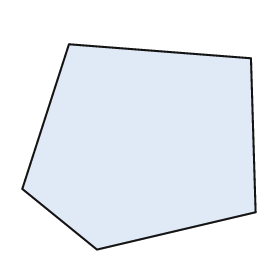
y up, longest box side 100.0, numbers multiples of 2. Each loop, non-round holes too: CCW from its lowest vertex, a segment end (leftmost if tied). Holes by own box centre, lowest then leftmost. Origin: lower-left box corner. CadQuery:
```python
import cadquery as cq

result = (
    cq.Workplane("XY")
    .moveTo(32.0, 0.0)
    .lineTo(100.0, 16.0)
    .lineTo(98.0, 82.0)
    .lineTo(20.0, 88.0)
    .lineTo(0.0, 26.0)
    .close()
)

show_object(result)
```